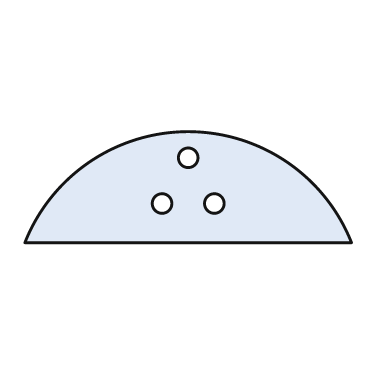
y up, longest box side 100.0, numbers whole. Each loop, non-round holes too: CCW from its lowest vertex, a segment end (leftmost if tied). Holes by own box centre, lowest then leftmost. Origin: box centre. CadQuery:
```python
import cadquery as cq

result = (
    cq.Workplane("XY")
    .moveTo(-50.0, -17.0)
    .lineTo(50.0, -17.0)
    .threePointArc((0.0, 17.0), (-50.0, -17.0))
    .close()
    .moveTo(-8.0, -5.0)
    .circle(3.0)
    .moveTo(8.0, -5.0)
    .circle(3.0)
    .moveTo(0.0, 9.0)
    .circle(3.0)
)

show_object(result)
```